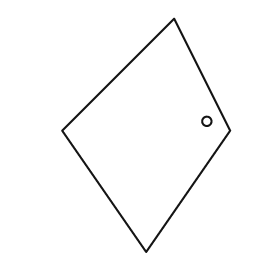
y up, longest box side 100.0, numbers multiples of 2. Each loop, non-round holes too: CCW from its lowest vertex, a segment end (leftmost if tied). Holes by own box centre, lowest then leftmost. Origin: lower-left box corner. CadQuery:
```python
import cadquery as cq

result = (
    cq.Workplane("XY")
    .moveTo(36.0, 0.0)
    .lineTo(72.0, 52.0)
    .lineTo(48.0, 100.0)
    .lineTo(0.0, 52.0)
    .close()
    .moveTo(62.0, 56.0)
    .circle(2.0)
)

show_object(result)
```